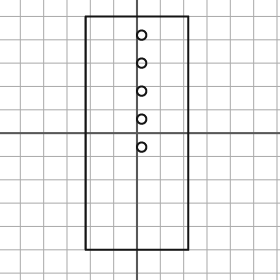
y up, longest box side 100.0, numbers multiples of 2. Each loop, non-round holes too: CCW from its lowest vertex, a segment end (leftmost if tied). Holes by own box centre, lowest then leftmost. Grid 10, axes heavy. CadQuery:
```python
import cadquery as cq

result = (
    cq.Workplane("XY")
    .moveTo(-22.0, -50.0)
    .lineTo(22.0, -50.0)
    .lineTo(22.0, 50.0)
    .lineTo(-22.0, 50.0)
    .close()
    .moveTo(2.0, -6.0)
    .circle(2.0)
    .moveTo(2.0, 6.0)
    .circle(2.0)
    .moveTo(2.0, 18.0)
    .circle(2.0)
    .moveTo(2.0, 30.0)
    .circle(2.0)
    .moveTo(2.0, 42.0)
    .circle(2.0)
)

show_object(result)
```